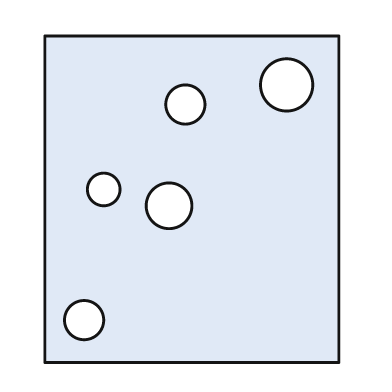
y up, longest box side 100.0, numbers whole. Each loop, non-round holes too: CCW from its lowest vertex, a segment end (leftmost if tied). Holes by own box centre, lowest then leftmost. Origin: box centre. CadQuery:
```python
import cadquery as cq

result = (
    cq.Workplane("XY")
    .moveTo(-45.0, -50.0)
    .lineTo(45.0, -50.0)
    .lineTo(45.0, 50.0)
    .lineTo(-45.0, 50.0)
    .close()
    .moveTo(-33.0, -37.0)
    .circle(6.0)
    .moveTo(-7.0, -2.0)
    .circle(7.0)
    .moveTo(-27.0, 3.0)
    .circle(5.0)
    .moveTo(-2.0, 29.0)
    .circle(6.0)
    .moveTo(29.0, 35.0)
    .circle(8.0)
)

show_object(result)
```